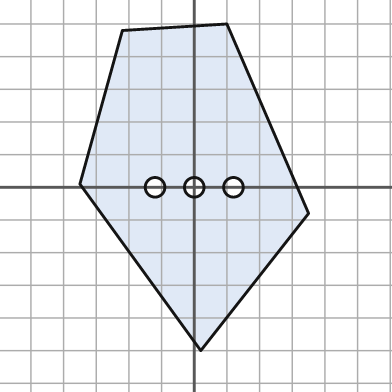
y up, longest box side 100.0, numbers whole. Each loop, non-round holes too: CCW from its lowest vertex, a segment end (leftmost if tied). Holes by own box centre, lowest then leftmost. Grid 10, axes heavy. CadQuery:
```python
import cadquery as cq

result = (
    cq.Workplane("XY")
    .moveTo(2.0, -50.0)
    .lineTo(35.0, -8.0)
    .lineTo(10.0, 50.0)
    .lineTo(-22.0, 48.0)
    .lineTo(-35.0, 1.0)
    .close()
    .moveTo(-12.0, 0.0)
    .circle(3.0)
    .moveTo(0.0, 0.0)
    .circle(3.0)
    .moveTo(12.0, 0.0)
    .circle(3.0)
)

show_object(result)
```